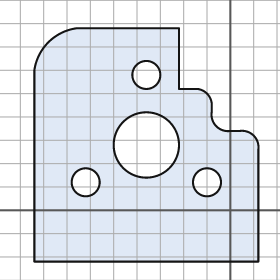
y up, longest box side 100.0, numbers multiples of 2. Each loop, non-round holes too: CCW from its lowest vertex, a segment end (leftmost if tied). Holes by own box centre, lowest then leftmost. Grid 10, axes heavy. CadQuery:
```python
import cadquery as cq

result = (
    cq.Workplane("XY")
    .moveTo(-84.0, -22.0)
    .lineTo(12.0, -22.0)
    .lineTo(12.0, 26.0)
    .threePointArc((10.0, 32.0), (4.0, 34.0))
    .lineTo(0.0, 34.0)
    .threePointArc((-6.0, 36.0), (-8.0, 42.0))
    .lineTo(-8.0, 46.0)
    .threePointArc((-10.0, 50.0), (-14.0, 52.0))
    .lineTo(-22.0, 52.0)
    .lineTo(-22.0, 78.0)
    .lineTo(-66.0, 78.0)
    .threePointArc((-78.0, 72.0), (-84.0, 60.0))
    .close()
    .moveTo(-62.0, 12.0)
    .circle(6.0)
    .moveTo(-10.0, 12.0)
    .circle(6.0)
    .moveTo(-36.0, 28.0)
    .circle(14.0)
    .moveTo(-36.0, 58.0)
    .circle(6.0)
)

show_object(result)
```